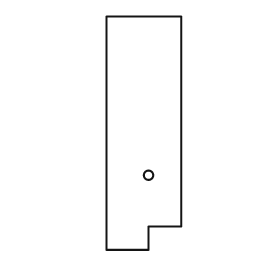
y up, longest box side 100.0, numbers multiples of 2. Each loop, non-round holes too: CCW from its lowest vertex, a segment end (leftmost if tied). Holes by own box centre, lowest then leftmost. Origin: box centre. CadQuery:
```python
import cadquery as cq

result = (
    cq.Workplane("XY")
    .moveTo(-16.0, -50.0)
    .lineTo(2.0, -50.0)
    .lineTo(2.0, -40.0)
    .lineTo(16.0, -40.0)
    .lineTo(16.0, 50.0)
    .lineTo(-16.0, 50.0)
    .close()
    .moveTo(2.0, -18.0)
    .circle(2.0)
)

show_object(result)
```